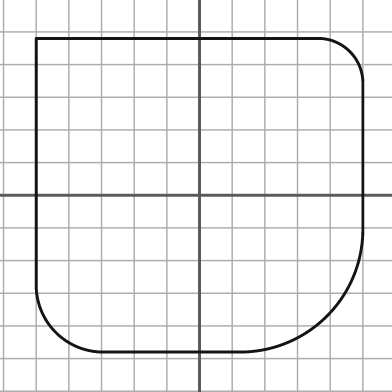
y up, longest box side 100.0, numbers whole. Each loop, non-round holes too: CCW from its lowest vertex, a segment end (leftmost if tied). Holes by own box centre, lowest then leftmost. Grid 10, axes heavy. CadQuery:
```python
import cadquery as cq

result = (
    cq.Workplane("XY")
    .moveTo(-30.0, -48.0)
    .lineTo(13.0, -48.0)
    .threePointArc((39.0, -37.0), (50.0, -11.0))
    .lineTo(50.0, 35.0)
    .threePointArc((46.0, 44.0), (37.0, 48.0))
    .lineTo(-50.0, 48.0)
    .lineTo(-50.0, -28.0)
    .threePointArc((-44.0, -42.0), (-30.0, -48.0))
    .close()
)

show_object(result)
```